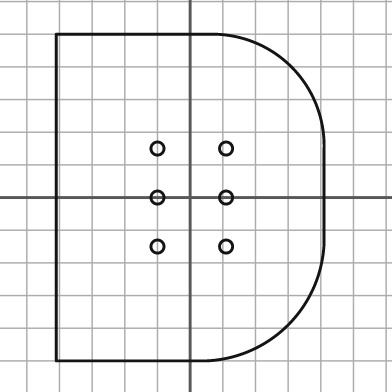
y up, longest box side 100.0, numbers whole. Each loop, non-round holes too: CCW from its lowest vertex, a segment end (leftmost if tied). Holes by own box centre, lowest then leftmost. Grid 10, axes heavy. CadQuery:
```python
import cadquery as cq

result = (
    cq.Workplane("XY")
    .moveTo(-41.0, -50.0)
    .lineTo(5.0, -50.0)
    .threePointArc((30.0, -39.0), (41.0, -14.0))
    .lineTo(41.0, 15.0)
    .threePointArc((31.0, 40.0), (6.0, 50.0))
    .lineTo(-41.0, 50.0)
    .close()
    .moveTo(-10.0, -15.0)
    .circle(2.0)
    .moveTo(11.0, -15.0)
    .circle(2.0)
    .moveTo(-10.0, 0.0)
    .circle(2.0)
    .moveTo(11.0, 0.0)
    .circle(2.0)
    .moveTo(-10.0, 15.0)
    .circle(2.0)
    .moveTo(11.0, 15.0)
    .circle(2.0)
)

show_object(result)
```